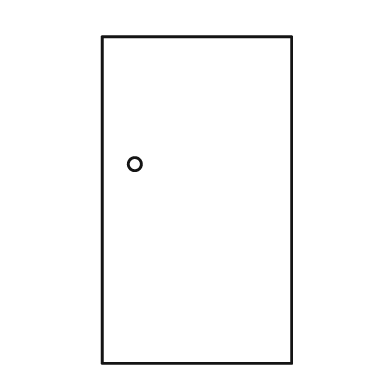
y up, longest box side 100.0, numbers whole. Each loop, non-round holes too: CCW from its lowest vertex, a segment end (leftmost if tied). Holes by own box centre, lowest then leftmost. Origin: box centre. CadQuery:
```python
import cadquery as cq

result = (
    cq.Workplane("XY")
    .moveTo(-29.0, -50.0)
    .lineTo(29.0, -50.0)
    .lineTo(29.0, 50.0)
    .lineTo(-29.0, 50.0)
    .close()
    .moveTo(-19.0, 11.0)
    .circle(2.0)
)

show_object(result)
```